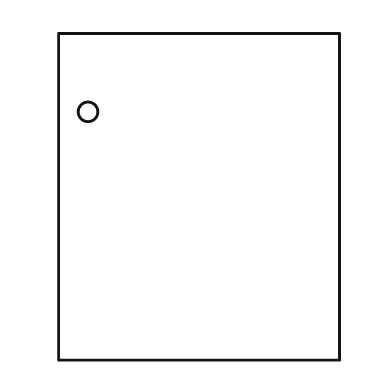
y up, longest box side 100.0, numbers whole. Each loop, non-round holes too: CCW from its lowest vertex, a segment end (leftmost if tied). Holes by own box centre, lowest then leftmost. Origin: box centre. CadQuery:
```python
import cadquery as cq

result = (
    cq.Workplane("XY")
    .moveTo(-43.0, -50.0)
    .lineTo(43.0, -50.0)
    .lineTo(43.0, 50.0)
    .lineTo(-43.0, 50.0)
    .close()
    .moveTo(-34.0, 26.0)
    .circle(3.0)
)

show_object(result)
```